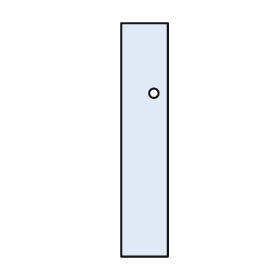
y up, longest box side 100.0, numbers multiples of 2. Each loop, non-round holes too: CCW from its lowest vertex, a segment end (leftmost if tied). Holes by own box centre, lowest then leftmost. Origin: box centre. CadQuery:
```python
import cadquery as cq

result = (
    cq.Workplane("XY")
    .moveTo(-10.0, -50.0)
    .lineTo(10.0, -50.0)
    .lineTo(10.0, 50.0)
    .lineTo(-10.0, 50.0)
    .close()
    .moveTo(4.0, 20.0)
    .circle(2.0)
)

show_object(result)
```